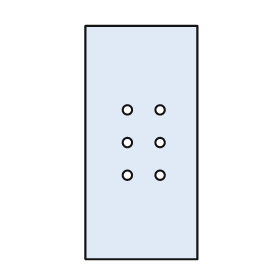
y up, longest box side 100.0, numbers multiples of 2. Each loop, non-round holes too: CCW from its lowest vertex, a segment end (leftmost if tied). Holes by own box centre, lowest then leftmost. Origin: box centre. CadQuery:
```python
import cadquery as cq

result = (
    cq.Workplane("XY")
    .moveTo(-24.0, -50.0)
    .lineTo(24.0, -50.0)
    .lineTo(24.0, 50.0)
    .lineTo(-24.0, 50.0)
    .close()
    .moveTo(-6.0, -14.0)
    .circle(2.0)
    .moveTo(8.0, -14.0)
    .circle(2.0)
    .moveTo(-6.0, 0.0)
    .circle(2.0)
    .moveTo(8.0, 0.0)
    .circle(2.0)
    .moveTo(-6.0, 14.0)
    .circle(2.0)
    .moveTo(8.0, 14.0)
    .circle(2.0)
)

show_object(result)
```